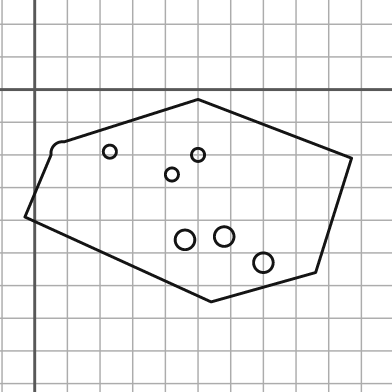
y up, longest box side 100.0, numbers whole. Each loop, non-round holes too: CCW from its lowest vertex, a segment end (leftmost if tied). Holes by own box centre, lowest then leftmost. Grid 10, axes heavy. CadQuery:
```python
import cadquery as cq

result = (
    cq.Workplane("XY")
    .moveTo(54.0, -65.0)
    .lineTo(86.0, -56.0)
    .lineTo(97.0, -21.0)
    .lineTo(50.0, -3.0)
    .lineTo(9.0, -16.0)
    .threePointArc((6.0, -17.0), (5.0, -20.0))
    .lineTo(-3.0, -39.0)
    .close()
    .moveTo(70.0, -53.0)
    .circle(3.0)
    .moveTo(46.0, -46.0)
    .circle(3.0)
    .moveTo(58.0, -45.0)
    .circle(3.0)
    .moveTo(42.0, -26.0)
    .circle(2.0)
    .moveTo(50.0, -20.0)
    .circle(2.0)
    .moveTo(23.0, -19.0)
    .circle(2.0)
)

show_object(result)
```